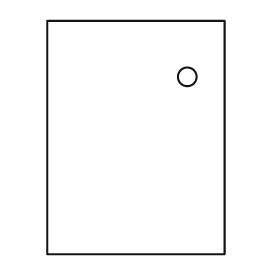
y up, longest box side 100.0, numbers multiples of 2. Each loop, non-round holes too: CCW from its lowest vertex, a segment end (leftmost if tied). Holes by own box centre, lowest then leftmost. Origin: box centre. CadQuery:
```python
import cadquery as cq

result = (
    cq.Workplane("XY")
    .moveTo(-38.0, -50.0)
    .lineTo(38.0, -50.0)
    .lineTo(38.0, 50.0)
    .lineTo(-38.0, 50.0)
    .close()
    .moveTo(22.0, 26.0)
    .circle(4.0)
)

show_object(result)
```